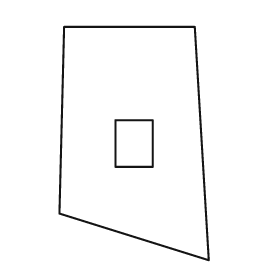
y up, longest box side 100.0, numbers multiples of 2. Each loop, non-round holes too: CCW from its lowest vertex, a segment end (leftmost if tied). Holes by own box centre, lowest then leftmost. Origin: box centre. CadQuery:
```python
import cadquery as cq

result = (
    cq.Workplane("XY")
    .moveTo(32.0, -50.0)
    .lineTo(26.0, 50.0)
    .lineTo(-30.0, 50.0)
    .lineTo(-32.0, -30.0)
    .close()
    .moveTo(-8.0, -10.0)
    .lineTo(8.0, -10.0)
    .lineTo(8.0, 10.0)
    .lineTo(-8.0, 10.0)
    .close()
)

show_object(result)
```